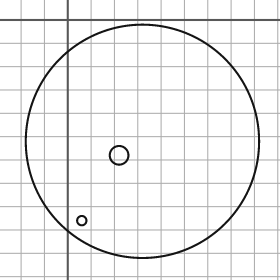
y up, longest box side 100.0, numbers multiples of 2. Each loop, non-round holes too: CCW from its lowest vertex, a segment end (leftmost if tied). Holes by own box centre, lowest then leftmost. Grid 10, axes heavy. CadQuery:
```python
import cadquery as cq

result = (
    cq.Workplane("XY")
    .moveTo(32.0, -52.0)
    .circle(50.0)
    .moveTo(6.0, -86.0)
    .circle(2.0)
    .moveTo(22.0, -58.0)
    .circle(4.0)
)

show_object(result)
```